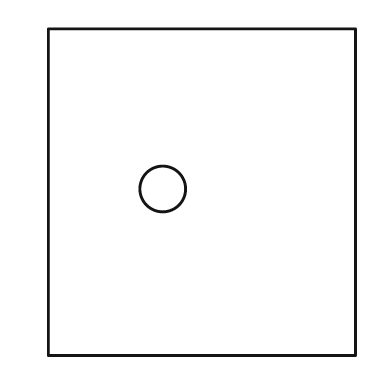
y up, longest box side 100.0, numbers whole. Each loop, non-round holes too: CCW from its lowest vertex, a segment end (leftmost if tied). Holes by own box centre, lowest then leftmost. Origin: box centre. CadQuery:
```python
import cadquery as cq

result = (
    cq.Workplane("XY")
    .moveTo(-47.0, -50.0)
    .lineTo(47.0, -50.0)
    .lineTo(47.0, 50.0)
    .lineTo(-47.0, 50.0)
    .close()
    .moveTo(-12.0, 1.0)
    .circle(7.0)
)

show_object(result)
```